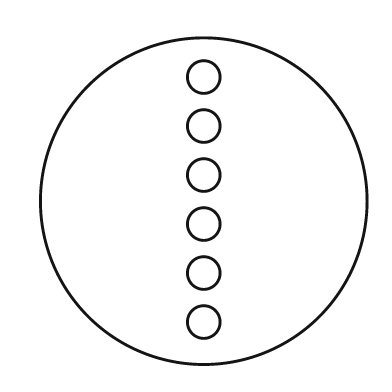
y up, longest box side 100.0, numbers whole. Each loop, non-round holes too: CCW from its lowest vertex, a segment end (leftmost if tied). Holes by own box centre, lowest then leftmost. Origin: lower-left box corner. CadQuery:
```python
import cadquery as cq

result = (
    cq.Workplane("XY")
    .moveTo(50.0, 50.0)
    .circle(50.0)
    .moveTo(50.0, 13.0)
    .circle(5.0)
    .moveTo(50.0, 28.0)
    .circle(5.0)
    .moveTo(50.0, 43.0)
    .circle(5.0)
    .moveTo(50.0, 58.0)
    .circle(5.0)
    .moveTo(50.0, 73.0)
    .circle(5.0)
    .moveTo(50.0, 88.0)
    .circle(5.0)
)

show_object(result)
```